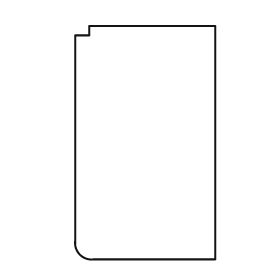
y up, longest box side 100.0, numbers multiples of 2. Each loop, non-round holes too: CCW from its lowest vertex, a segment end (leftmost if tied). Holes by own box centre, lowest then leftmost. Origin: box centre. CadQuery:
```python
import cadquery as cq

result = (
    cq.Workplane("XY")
    .moveTo(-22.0, -50.0)
    .lineTo(30.0, -50.0)
    .lineTo(30.0, 50.0)
    .lineTo(-24.0, 50.0)
    .lineTo(-24.0, 46.0)
    .lineTo(-30.0, 46.0)
    .lineTo(-30.0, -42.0)
    .threePointArc((-28.0, -48.0), (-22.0, -50.0))
    .close()
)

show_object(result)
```